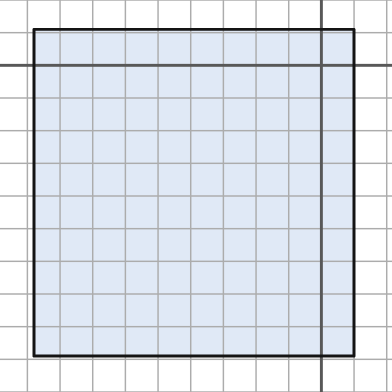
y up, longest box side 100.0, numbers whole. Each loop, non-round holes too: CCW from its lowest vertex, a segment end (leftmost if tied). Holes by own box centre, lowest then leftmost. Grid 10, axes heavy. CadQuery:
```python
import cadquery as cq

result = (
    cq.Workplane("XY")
    .moveTo(-88.0, -89.0)
    .lineTo(10.0, -89.0)
    .lineTo(10.0, 11.0)
    .lineTo(-88.0, 11.0)
    .close()
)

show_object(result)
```